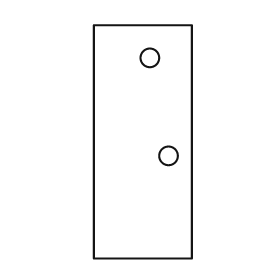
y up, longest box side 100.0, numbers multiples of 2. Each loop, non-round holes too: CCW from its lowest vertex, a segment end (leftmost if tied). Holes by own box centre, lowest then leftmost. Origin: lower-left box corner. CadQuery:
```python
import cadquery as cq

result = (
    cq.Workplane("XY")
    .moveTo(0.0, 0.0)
    .lineTo(42.0, 0.0)
    .lineTo(42.0, 100.0)
    .lineTo(0.0, 100.0)
    .close()
    .moveTo(32.0, 44.0)
    .circle(4.0)
    .moveTo(24.0, 86.0)
    .circle(4.0)
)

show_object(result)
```